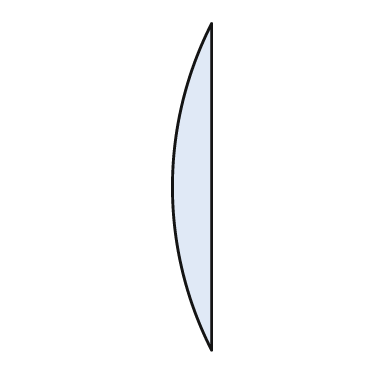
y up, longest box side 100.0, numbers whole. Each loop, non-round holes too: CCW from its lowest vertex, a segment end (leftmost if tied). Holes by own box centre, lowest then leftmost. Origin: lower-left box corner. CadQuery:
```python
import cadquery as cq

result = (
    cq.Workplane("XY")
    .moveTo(12.0, 0.0)
    .lineTo(12.0, 100.0)
    .threePointArc((0.0, 50.0), (12.0, 0.0))
    .close()
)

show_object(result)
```